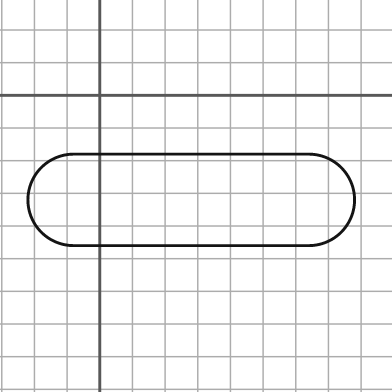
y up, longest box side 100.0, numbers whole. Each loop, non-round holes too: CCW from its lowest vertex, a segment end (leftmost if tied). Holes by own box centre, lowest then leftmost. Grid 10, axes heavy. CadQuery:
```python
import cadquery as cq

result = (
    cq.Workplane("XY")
    .moveTo(-8.0, -46.0)
    .lineTo(64.0, -46.0)
    .threePointArc((78.0, -32.0), (64.0, -18.0))
    .lineTo(-8.0, -18.0)
    .threePointArc((-22.0, -32.0), (-8.0, -46.0))
    .close()
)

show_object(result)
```